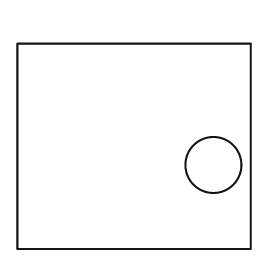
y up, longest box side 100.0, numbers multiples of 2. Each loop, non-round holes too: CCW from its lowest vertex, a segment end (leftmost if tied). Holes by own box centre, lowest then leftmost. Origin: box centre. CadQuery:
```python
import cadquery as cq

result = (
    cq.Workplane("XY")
    .moveTo(-50.0, -44.0)
    .lineTo(50.0, -44.0)
    .lineTo(50.0, 44.0)
    .lineTo(-50.0, 44.0)
    .close()
    .moveTo(34.0, -8.0)
    .circle(12.0)
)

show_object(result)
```